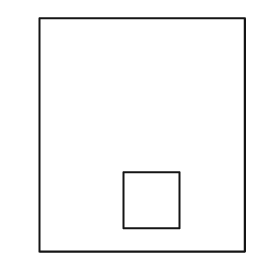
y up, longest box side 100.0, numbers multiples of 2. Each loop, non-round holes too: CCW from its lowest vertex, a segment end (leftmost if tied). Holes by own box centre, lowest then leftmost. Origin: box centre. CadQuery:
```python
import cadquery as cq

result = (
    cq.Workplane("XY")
    .moveTo(-44.0, -50.0)
    .lineTo(44.0, -50.0)
    .lineTo(44.0, 50.0)
    .lineTo(-44.0, 50.0)
    .close()
    .moveTo(-8.0, -40.0)
    .lineTo(16.0, -40.0)
    .lineTo(16.0, -16.0)
    .lineTo(-8.0, -16.0)
    .close()
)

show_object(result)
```